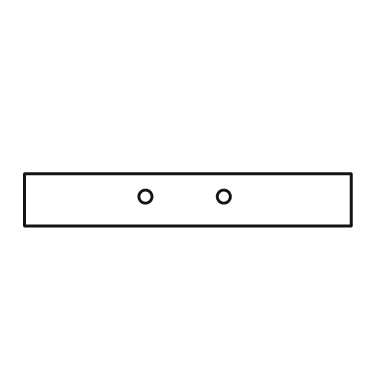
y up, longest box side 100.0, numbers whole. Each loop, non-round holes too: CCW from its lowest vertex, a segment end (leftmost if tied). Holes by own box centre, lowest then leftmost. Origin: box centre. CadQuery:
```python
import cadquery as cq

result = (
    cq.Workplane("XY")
    .moveTo(-50.0, -8.0)
    .lineTo(50.0, -8.0)
    .lineTo(50.0, 8.0)
    .lineTo(-50.0, 8.0)
    .close()
    .moveTo(-13.0, 1.0)
    .circle(2.0)
    .moveTo(11.0, 1.0)
    .circle(2.0)
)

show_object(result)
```